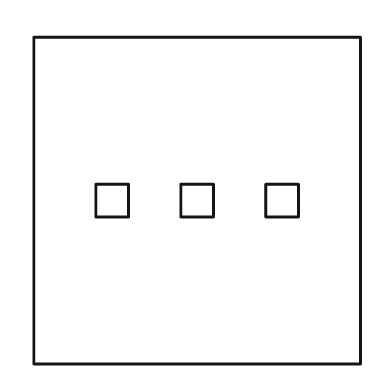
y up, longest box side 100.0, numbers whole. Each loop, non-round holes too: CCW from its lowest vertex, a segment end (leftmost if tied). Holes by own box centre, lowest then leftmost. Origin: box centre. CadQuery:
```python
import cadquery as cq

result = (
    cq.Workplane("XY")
    .moveTo(-50.0, -50.0)
    .lineTo(50.0, -50.0)
    .lineTo(50.0, 50.0)
    .lineTo(-50.0, 50.0)
    .close()
    .moveTo(-31.0, -5.0)
    .lineTo(-21.0, -5.0)
    .lineTo(-21.0, 5.0)
    .lineTo(-31.0, 5.0)
    .close()
    .moveTo(-5.0, -5.0)
    .lineTo(5.0, -5.0)
    .lineTo(5.0, 5.0)
    .lineTo(-5.0, 5.0)
    .close()
    .moveTo(21.0, -5.0)
    .lineTo(31.0, -5.0)
    .lineTo(31.0, 5.0)
    .lineTo(21.0, 5.0)
    .close()
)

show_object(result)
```